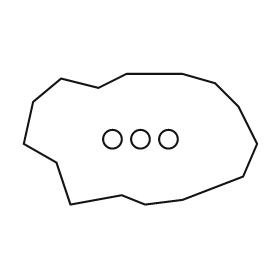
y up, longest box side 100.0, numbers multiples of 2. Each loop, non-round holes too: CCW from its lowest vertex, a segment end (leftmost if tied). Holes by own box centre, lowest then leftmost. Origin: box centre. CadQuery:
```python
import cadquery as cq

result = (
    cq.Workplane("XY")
    .moveTo(-30.0, -28.0)
    .lineTo(-8.0, -24.0)
    .lineTo(2.0, -28.0)
    .lineTo(18.0, -26.0)
    .lineTo(44.0, -16.0)
    .lineTo(50.0, -2.0)
    .lineTo(42.0, 14.0)
    .lineTo(32.0, 24.0)
    .lineTo(18.0, 28.0)
    .lineTo(-6.0, 28.0)
    .lineTo(-18.0, 22.0)
    .lineTo(-34.0, 26.0)
    .lineTo(-46.0, 16.0)
    .lineTo(-50.0, -2.0)
    .lineTo(-36.0, -10.0)
    .close()
    .moveTo(-12.0, 0.0)
    .circle(4.0)
    .moveTo(0.0, 0.0)
    .circle(4.0)
    .moveTo(12.0, 0.0)
    .circle(4.0)
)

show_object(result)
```